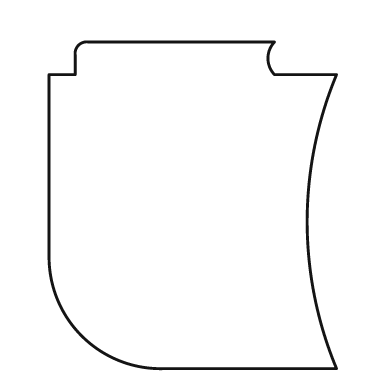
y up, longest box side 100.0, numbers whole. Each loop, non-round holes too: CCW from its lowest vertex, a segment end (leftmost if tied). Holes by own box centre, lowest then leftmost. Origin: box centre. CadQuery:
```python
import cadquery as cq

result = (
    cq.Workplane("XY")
    .moveTo(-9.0, -50.0)
    .lineTo(44.0, -50.0)
    .threePointArc((35.0, -5.0), (44.0, 40.0))
    .lineTo(25.0, 40.0)
    .threePointArc((23.0, 45.0), (25.0, 50.0))
    .lineTo(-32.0, 50.0)
    .threePointArc((-35.0, 49.0), (-36.0, 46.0))
    .lineTo(-36.0, 40.0)
    .lineTo(-44.0, 40.0)
    .lineTo(-44.0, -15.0)
    .threePointArc((-34.0, -40.0), (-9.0, -50.0))
    .close()
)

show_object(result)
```